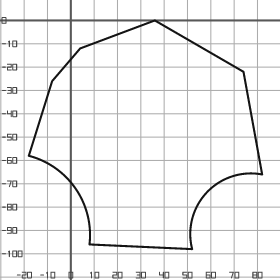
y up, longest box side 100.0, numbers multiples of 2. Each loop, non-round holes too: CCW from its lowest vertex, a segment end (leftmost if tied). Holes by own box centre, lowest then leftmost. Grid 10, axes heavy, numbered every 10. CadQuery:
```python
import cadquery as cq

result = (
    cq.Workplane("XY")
    .moveTo(52.0, -98.0)
    .threePointArc((58.0, -74.0), (82.0, -66.0))
    .lineTo(74.0, -22.0)
    .lineTo(36.0, 0.0)
    .lineTo(4.0, -12.0)
    .lineTo(-8.0, -26.0)
    .lineTo(-18.0, -58.0)
    .threePointArc((2.0, -72.0), (8.0, -96.0))
    .close()
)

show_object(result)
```